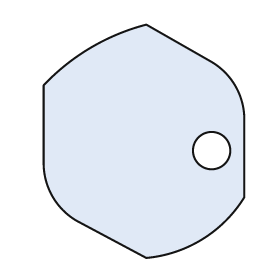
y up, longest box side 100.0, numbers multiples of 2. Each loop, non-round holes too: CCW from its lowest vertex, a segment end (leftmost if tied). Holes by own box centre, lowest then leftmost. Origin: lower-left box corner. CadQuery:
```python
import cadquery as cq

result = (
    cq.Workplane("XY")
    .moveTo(44.0, 0.0)
    .threePointArc((68.0, 8.0), (86.0, 26.0))
    .lineTo(86.0, 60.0)
    .threePointArc((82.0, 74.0), (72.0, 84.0))
    .lineTo(44.0, 100.0)
    .threePointArc((20.0, 90.0), (0.0, 74.0))
    .lineTo(0.0, 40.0)
    .threePointArc((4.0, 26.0), (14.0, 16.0))
    .close()
    .moveTo(72.0, 46.0)
    .circle(8.0)
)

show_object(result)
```